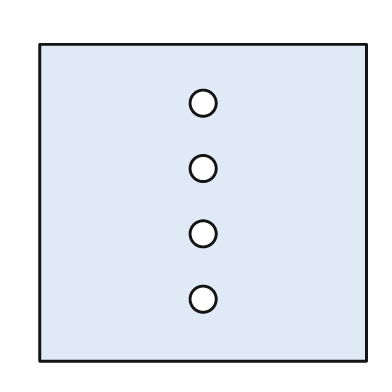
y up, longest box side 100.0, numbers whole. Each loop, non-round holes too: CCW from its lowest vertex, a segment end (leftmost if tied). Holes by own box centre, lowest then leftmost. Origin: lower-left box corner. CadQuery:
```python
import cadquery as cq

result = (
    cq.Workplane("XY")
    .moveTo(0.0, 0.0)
    .lineTo(100.0, 0.0)
    .lineTo(100.0, 97.0)
    .lineTo(0.0, 97.0)
    .close()
    .moveTo(50.0, 19.0)
    .circle(4.0)
    .moveTo(50.0, 39.0)
    .circle(4.0)
    .moveTo(50.0, 59.0)
    .circle(4.0)
    .moveTo(50.0, 79.0)
    .circle(4.0)
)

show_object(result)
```